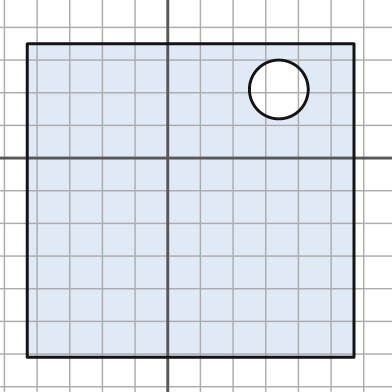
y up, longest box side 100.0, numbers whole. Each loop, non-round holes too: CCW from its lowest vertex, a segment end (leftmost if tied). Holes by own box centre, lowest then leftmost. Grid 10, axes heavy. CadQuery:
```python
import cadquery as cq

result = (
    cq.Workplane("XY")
    .moveTo(-43.0, -61.0)
    .lineTo(57.0, -61.0)
    .lineTo(57.0, 35.0)
    .lineTo(-43.0, 35.0)
    .close()
    .moveTo(34.0, 21.0)
    .circle(9.0)
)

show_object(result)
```